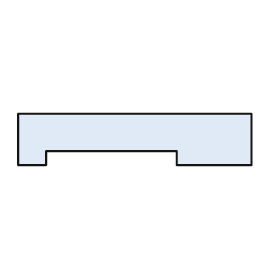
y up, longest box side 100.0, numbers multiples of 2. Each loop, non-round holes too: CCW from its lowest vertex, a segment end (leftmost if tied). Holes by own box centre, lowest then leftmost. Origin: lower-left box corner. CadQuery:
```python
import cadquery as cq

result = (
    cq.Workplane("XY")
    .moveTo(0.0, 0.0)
    .lineTo(12.0, 0.0)
    .lineTo(12.0, 6.0)
    .lineTo(68.0, 6.0)
    .lineTo(68.0, 0.0)
    .lineTo(100.0, 0.0)
    .lineTo(100.0, 22.0)
    .lineTo(0.0, 22.0)
    .close()
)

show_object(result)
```